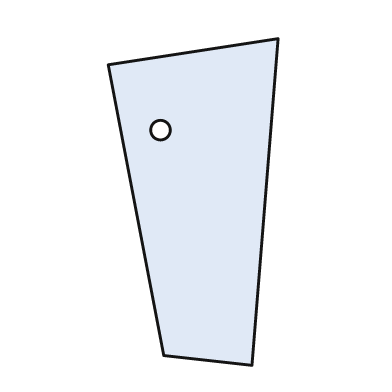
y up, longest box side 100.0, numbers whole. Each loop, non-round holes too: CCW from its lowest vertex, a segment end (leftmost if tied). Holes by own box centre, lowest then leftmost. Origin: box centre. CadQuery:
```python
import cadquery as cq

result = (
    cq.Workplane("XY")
    .moveTo(18.0, -50.0)
    .lineTo(26.0, 50.0)
    .lineTo(-26.0, 42.0)
    .lineTo(-9.0, -47.0)
    .close()
    .moveTo(-10.0, 22.0)
    .circle(3.0)
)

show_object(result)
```